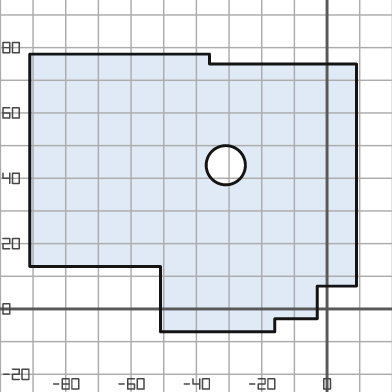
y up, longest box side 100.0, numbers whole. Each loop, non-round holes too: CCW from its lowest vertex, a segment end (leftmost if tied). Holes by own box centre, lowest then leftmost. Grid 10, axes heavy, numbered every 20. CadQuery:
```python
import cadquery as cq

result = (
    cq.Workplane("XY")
    .moveTo(-51.0, -7.0)
    .lineTo(-16.0, -7.0)
    .lineTo(-16.0, -3.0)
    .lineTo(-3.0, -3.0)
    .lineTo(-3.0, 7.0)
    .lineTo(9.0, 7.0)
    .lineTo(9.0, 75.0)
    .lineTo(-36.0, 75.0)
    .lineTo(-36.0, 78.0)
    .lineTo(-91.0, 78.0)
    .lineTo(-91.0, 13.0)
    .lineTo(-51.0, 13.0)
    .close()
    .moveTo(-31.0, 44.0)
    .circle(6.0)
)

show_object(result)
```